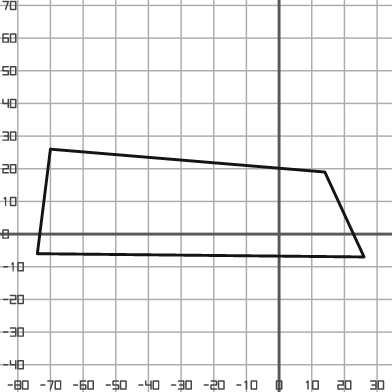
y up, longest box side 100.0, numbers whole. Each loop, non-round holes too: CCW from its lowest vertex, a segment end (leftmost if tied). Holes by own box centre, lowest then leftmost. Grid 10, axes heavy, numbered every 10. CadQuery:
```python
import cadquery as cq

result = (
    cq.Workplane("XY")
    .moveTo(26.0, -7.0)
    .lineTo(14.0, 19.0)
    .lineTo(-70.0, 26.0)
    .lineTo(-74.0, -6.0)
    .close()
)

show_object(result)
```